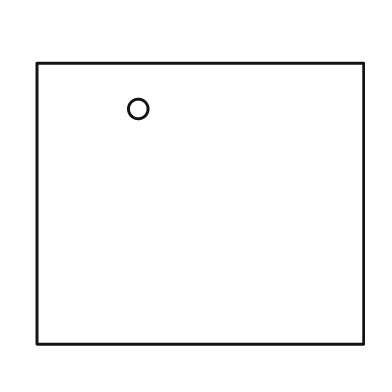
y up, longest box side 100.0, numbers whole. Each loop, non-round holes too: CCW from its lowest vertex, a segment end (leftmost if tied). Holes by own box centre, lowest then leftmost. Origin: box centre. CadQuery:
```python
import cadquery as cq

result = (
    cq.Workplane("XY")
    .moveTo(-50.0, -43.0)
    .lineTo(50.0, -43.0)
    .lineTo(50.0, 43.0)
    .lineTo(-50.0, 43.0)
    .close()
    .moveTo(-19.0, 29.0)
    .circle(3.0)
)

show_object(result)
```